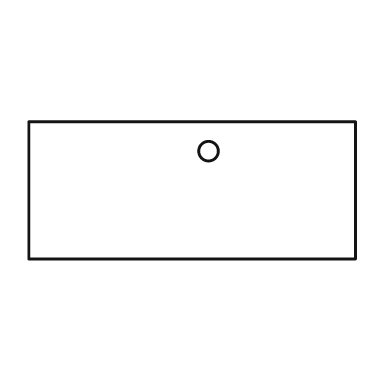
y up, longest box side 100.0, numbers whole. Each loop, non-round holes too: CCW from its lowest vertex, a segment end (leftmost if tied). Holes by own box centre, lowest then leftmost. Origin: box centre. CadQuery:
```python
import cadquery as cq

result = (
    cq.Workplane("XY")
    .moveTo(-50.0, -21.0)
    .lineTo(50.0, -21.0)
    .lineTo(50.0, 21.0)
    .lineTo(-50.0, 21.0)
    .close()
    .moveTo(5.0, 12.0)
    .circle(3.0)
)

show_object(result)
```